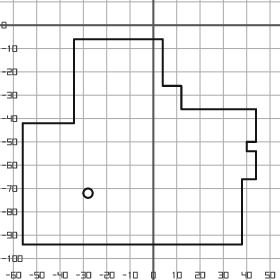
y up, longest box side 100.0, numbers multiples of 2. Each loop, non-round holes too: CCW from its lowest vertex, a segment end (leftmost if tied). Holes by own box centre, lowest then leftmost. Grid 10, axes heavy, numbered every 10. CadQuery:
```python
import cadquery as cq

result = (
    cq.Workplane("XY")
    .moveTo(-56.0, -94.0)
    .lineTo(38.0, -94.0)
    .lineTo(38.0, -66.0)
    .lineTo(44.0, -66.0)
    .lineTo(44.0, -54.0)
    .lineTo(40.0, -54.0)
    .lineTo(40.0, -50.0)
    .lineTo(44.0, -50.0)
    .lineTo(44.0, -36.0)
    .lineTo(12.0, -36.0)
    .lineTo(12.0, -26.0)
    .lineTo(4.0, -26.0)
    .lineTo(4.0, -6.0)
    .lineTo(-34.0, -6.0)
    .lineTo(-34.0, -42.0)
    .lineTo(-56.0, -42.0)
    .close()
    .moveTo(-28.0, -72.0)
    .circle(2.0)
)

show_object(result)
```